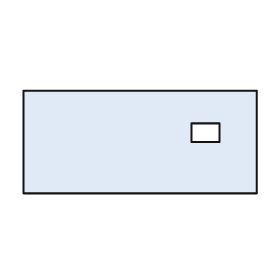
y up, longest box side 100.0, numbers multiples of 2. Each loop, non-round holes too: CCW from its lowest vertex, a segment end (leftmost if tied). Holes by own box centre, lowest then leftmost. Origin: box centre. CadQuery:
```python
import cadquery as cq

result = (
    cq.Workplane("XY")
    .moveTo(-50.0, -22.0)
    .lineTo(50.0, -22.0)
    .lineTo(50.0, 22.0)
    .lineTo(-50.0, 22.0)
    .close()
    .moveTo(22.0, 0.0)
    .lineTo(34.0, 0.0)
    .lineTo(34.0, 8.0)
    .lineTo(22.0, 8.0)
    .close()
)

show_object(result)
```